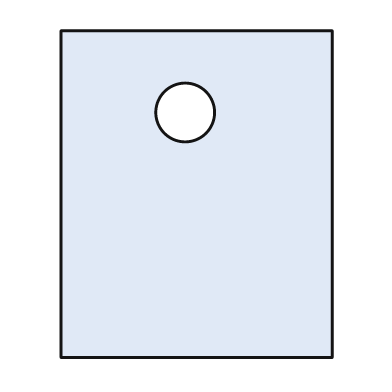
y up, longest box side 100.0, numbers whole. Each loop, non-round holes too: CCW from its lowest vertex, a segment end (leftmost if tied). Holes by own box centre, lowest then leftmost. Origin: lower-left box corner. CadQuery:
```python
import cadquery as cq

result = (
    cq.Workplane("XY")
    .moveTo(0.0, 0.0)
    .lineTo(83.0, 0.0)
    .lineTo(83.0, 100.0)
    .lineTo(0.0, 100.0)
    .close()
    .moveTo(38.0, 75.0)
    .circle(9.0)
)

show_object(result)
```